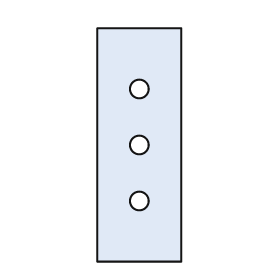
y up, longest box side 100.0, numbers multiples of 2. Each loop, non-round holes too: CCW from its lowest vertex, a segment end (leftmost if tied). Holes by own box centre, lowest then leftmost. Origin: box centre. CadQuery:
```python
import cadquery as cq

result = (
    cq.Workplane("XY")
    .moveTo(-18.0, -50.0)
    .lineTo(18.0, -50.0)
    .lineTo(18.0, 50.0)
    .lineTo(-18.0, 50.0)
    .close()
    .moveTo(0.0, -24.0)
    .circle(4.0)
    .moveTo(0.0, 0.0)
    .circle(4.0)
    .moveTo(0.0, 24.0)
    .circle(4.0)
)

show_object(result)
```